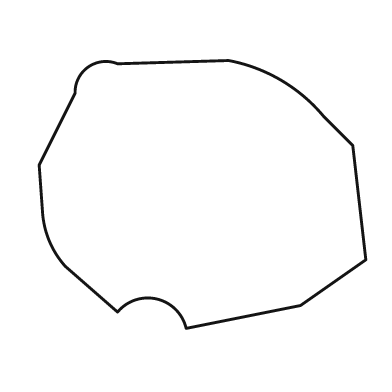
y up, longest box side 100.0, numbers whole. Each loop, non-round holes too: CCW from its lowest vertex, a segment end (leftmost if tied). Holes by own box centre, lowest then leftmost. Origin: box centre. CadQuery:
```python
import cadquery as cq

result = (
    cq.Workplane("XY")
    .moveTo(-5.0, -41.0)
    .lineTo(30.0, -34.0)
    .lineTo(50.0, -20.0)
    .lineTo(46.0, 15.0)
    .lineTo(37.0, 24.0)
    .threePointArc((24.0, 35.0), (8.0, 41.0))
    .lineTo(-26.0, 40.0)
    .threePointArc((-35.0, 39.0), (-39.0, 31.0))
    .lineTo(-50.0, 9.0)
    .lineTo(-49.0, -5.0)
    .threePointArc((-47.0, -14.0), (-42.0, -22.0))
    .lineTo(-26.0, -36.0)
    .threePointArc((-14.0, -32.0), (-5.0, -41.0))
    .close()
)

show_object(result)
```